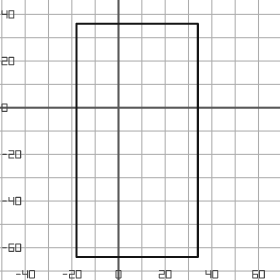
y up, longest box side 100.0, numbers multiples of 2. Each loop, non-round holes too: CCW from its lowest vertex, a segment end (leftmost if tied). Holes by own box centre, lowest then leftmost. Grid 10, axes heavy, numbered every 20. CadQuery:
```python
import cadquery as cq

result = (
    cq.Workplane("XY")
    .moveTo(-18.0, -64.0)
    .lineTo(34.0, -64.0)
    .lineTo(34.0, 36.0)
    .lineTo(-18.0, 36.0)
    .close()
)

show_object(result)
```